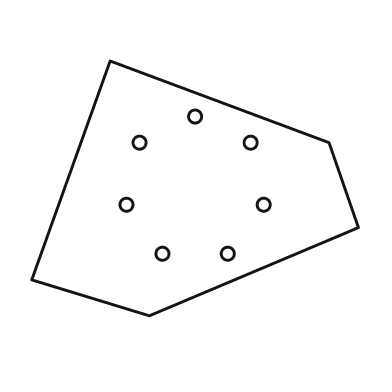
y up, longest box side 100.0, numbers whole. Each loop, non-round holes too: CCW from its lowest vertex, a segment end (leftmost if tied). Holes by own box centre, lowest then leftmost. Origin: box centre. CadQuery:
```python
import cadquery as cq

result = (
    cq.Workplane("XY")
    .moveTo(-14.0, -39.0)
    .lineTo(50.0, -12.0)
    .lineTo(41.0, 14.0)
    .lineTo(-26.0, 39.0)
    .lineTo(-50.0, -28.0)
    .close()
    .moveTo(-10.0, -20.0)
    .circle(2.0)
    .moveTo(10.0, -20.0)
    .circle(2.0)
    .moveTo(-21.0, -5.0)
    .circle(2.0)
    .moveTo(21.0, -5.0)
    .circle(2.0)
    .moveTo(-17.0, 14.0)
    .circle(2.0)
    .moveTo(17.0, 14.0)
    .circle(2.0)
    .moveTo(0.0, 22.0)
    .circle(2.0)
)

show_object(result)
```